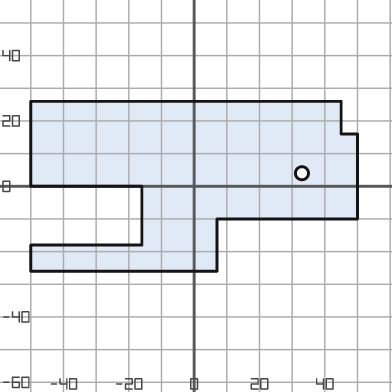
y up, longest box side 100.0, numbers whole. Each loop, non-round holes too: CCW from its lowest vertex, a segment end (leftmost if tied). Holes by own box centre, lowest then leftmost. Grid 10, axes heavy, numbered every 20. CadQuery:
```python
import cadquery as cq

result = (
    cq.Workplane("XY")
    .moveTo(-50.0, -26.0)
    .lineTo(7.0, -26.0)
    .lineTo(7.0, -10.0)
    .lineTo(50.0, -10.0)
    .lineTo(50.0, 16.0)
    .lineTo(45.0, 16.0)
    .lineTo(45.0, 26.0)
    .lineTo(-50.0, 26.0)
    .lineTo(-50.0, 0.0)
    .lineTo(-16.0, 0.0)
    .lineTo(-16.0, -18.0)
    .lineTo(-50.0, -18.0)
    .close()
    .moveTo(33.0, 4.0)
    .circle(2.0)
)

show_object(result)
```